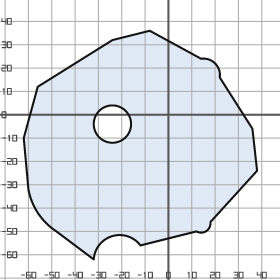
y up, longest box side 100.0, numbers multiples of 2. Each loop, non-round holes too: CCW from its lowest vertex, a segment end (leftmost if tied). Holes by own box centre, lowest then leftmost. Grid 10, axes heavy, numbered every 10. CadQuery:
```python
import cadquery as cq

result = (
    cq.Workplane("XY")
    .moveTo(-32.0, -62.0)
    .threePointArc((-24.0, -52.0), (-12.0, -56.0))
    .lineTo(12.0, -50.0)
    .threePointArc((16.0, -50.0), (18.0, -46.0))
    .lineTo(38.0, -24.0)
    .lineTo(36.0, -6.0)
    .lineTo(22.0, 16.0)
    .threePointArc((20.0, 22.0), (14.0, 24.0))
    .lineTo(-8.0, 36.0)
    .lineTo(-24.0, 32.0)
    .lineTo(-56.0, 12.0)
    .lineTo(-62.0, -10.0)
    .lineTo(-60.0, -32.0)
    .threePointArc((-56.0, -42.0), (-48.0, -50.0))
    .close()
    .moveTo(-24.0, -4.0)
    .circle(8.0)
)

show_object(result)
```